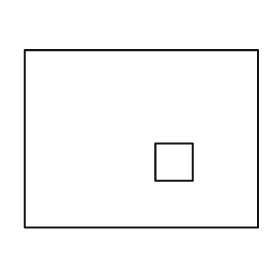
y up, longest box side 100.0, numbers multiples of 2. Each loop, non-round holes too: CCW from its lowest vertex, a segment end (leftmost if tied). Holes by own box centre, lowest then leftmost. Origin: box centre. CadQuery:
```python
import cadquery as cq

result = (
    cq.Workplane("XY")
    .moveTo(-50.0, -38.0)
    .lineTo(50.0, -38.0)
    .lineTo(50.0, 38.0)
    .lineTo(-50.0, 38.0)
    .close()
    .moveTo(6.0, -18.0)
    .lineTo(22.0, -18.0)
    .lineTo(22.0, -2.0)
    .lineTo(6.0, -2.0)
    .close()
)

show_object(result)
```